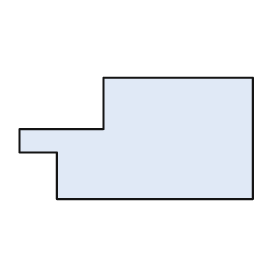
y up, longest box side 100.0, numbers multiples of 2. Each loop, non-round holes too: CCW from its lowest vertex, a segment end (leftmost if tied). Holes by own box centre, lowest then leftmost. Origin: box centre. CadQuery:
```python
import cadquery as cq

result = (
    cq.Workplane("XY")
    .moveTo(-34.0, -26.0)
    .lineTo(50.0, -26.0)
    .lineTo(50.0, 26.0)
    .lineTo(-14.0, 26.0)
    .lineTo(-14.0, 4.0)
    .lineTo(-50.0, 4.0)
    .lineTo(-50.0, -6.0)
    .lineTo(-34.0, -6.0)
    .close()
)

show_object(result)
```